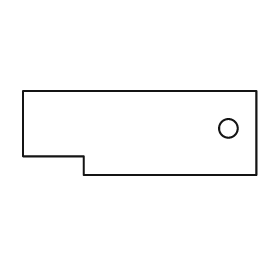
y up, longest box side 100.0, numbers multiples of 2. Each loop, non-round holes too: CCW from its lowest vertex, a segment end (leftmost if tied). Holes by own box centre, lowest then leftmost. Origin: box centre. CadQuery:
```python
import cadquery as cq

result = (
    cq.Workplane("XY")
    .moveTo(-24.0, -18.0)
    .lineTo(50.0, -18.0)
    .lineTo(50.0, 18.0)
    .lineTo(-50.0, 18.0)
    .lineTo(-50.0, -10.0)
    .lineTo(-24.0, -10.0)
    .close()
    .moveTo(38.0, 2.0)
    .circle(4.0)
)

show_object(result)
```